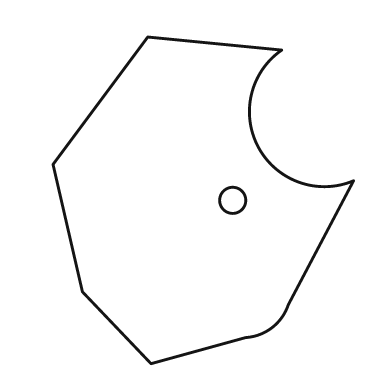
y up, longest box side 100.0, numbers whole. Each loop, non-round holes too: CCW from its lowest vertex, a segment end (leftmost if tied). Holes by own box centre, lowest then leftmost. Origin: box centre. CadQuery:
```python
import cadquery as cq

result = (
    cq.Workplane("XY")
    .moveTo(-16.0, -50.0)
    .lineTo(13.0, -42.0)
    .threePointArc((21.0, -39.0), (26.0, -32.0))
    .lineTo(46.0, 6.0)
    .threePointArc((17.0, 16.0), (24.0, 46.0))
    .lineTo(-17.0, 50.0)
    .lineTo(-46.0, 11.0)
    .lineTo(-37.0, -28.0)
    .close()
    .moveTo(9.0, 0.0)
    .circle(4.0)
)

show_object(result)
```